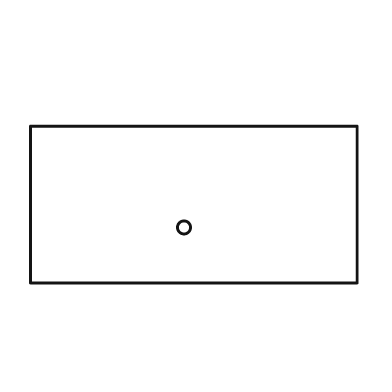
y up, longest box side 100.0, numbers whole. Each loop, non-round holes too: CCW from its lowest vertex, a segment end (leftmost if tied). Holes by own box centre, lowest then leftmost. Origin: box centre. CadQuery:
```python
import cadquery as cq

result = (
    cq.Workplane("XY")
    .moveTo(-50.0, -24.0)
    .lineTo(50.0, -24.0)
    .lineTo(50.0, 24.0)
    .lineTo(-50.0, 24.0)
    .close()
    .moveTo(-3.0, -7.0)
    .circle(2.0)
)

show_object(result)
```